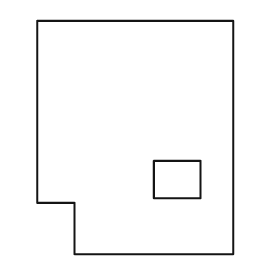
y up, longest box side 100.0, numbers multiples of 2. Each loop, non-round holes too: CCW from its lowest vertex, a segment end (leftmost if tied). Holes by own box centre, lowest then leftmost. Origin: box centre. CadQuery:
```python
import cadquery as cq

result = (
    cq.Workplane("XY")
    .moveTo(-26.0, -50.0)
    .lineTo(42.0, -50.0)
    .lineTo(42.0, 50.0)
    .lineTo(-42.0, 50.0)
    .lineTo(-42.0, -28.0)
    .lineTo(-26.0, -28.0)
    .close()
    .moveTo(8.0, -26.0)
    .lineTo(28.0, -26.0)
    .lineTo(28.0, -10.0)
    .lineTo(8.0, -10.0)
    .close()
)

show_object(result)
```